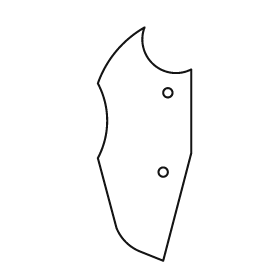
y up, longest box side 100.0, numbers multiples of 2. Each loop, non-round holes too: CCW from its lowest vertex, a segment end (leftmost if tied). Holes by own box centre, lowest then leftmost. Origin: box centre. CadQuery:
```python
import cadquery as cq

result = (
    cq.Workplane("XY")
    .moveTo(8.0, -50.0)
    .lineTo(20.0, -4.0)
    .lineTo(20.0, 32.0)
    .threePointArc((4.0, 34.0), (0.0, 50.0))
    .threePointArc((-12.0, 40.0), (-20.0, 26.0))
    .threePointArc((-16.0, 10.0), (-20.0, -6.0))
    .lineTo(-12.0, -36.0)
    .threePointArc((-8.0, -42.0), (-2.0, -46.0))
    .close()
    .moveTo(8.0, -12.0)
    .circle(2.0)
    .moveTo(10.0, 22.0)
    .circle(2.0)
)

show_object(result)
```